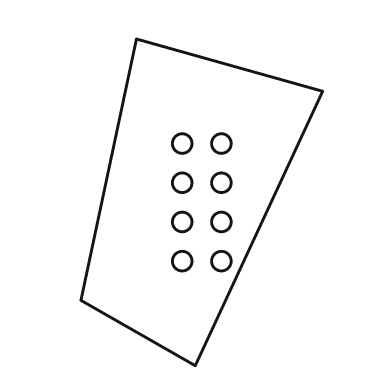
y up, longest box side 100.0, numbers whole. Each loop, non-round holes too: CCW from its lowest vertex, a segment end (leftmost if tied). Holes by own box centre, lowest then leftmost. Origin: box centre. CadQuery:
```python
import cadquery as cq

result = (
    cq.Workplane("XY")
    .moveTo(-2.0, -50.0)
    .lineTo(37.0, 34.0)
    .lineTo(-20.0, 50.0)
    .lineTo(-37.0, -30.0)
    .close()
    .moveTo(-6.0, -18.0)
    .circle(3.0)
    .moveTo(6.0, -18.0)
    .circle(3.0)
    .moveTo(-6.0, -6.0)
    .circle(3.0)
    .moveTo(6.0, -6.0)
    .circle(3.0)
    .moveTo(-6.0, 6.0)
    .circle(3.0)
    .moveTo(6.0, 6.0)
    .circle(3.0)
    .moveTo(-6.0, 18.0)
    .circle(3.0)
    .moveTo(6.0, 18.0)
    .circle(3.0)
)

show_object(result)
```